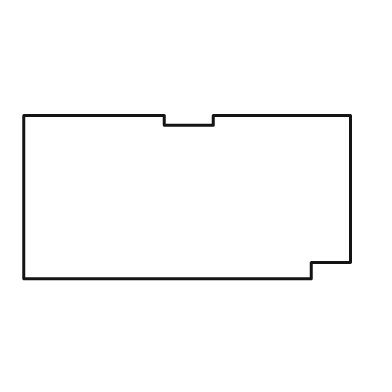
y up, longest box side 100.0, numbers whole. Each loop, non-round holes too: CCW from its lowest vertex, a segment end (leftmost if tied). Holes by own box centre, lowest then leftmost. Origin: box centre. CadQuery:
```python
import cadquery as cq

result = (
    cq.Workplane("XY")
    .moveTo(-50.0, -25.0)
    .lineTo(38.0, -25.0)
    .lineTo(38.0, -20.0)
    .lineTo(50.0, -20.0)
    .lineTo(50.0, 25.0)
    .lineTo(8.0, 25.0)
    .lineTo(8.0, 22.0)
    .lineTo(-7.0, 22.0)
    .lineTo(-7.0, 25.0)
    .lineTo(-50.0, 25.0)
    .close()
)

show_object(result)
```